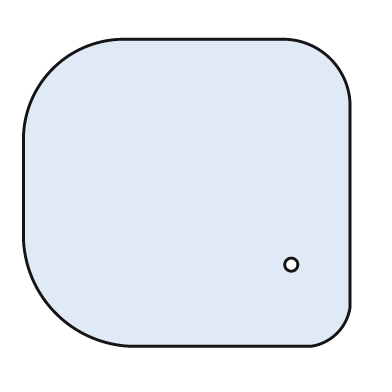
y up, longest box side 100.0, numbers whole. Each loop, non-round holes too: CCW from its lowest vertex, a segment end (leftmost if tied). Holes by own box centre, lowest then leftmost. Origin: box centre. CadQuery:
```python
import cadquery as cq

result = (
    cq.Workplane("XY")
    .moveTo(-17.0, -47.0)
    .lineTo(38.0, -47.0)
    .threePointArc((46.0, -43.0), (50.0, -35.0))
    .lineTo(50.0, 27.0)
    .threePointArc((44.0, 41.0), (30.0, 47.0))
    .lineTo(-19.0, 47.0)
    .threePointArc((-41.0, 38.0), (-50.0, 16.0))
    .lineTo(-50.0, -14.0)
    .threePointArc((-40.0, -37.0), (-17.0, -47.0))
    .close()
    .moveTo(32.0, -22.0)
    .circle(2.0)
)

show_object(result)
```